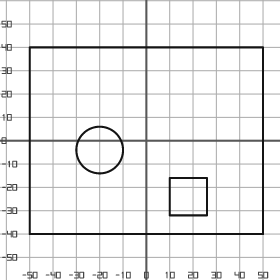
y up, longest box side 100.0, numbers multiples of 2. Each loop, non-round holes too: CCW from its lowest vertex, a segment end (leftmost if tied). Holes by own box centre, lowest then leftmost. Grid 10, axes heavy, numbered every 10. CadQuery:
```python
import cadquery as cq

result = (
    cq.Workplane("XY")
    .moveTo(-50.0, -40.0)
    .lineTo(50.0, -40.0)
    .lineTo(50.0, 40.0)
    .lineTo(-50.0, 40.0)
    .close()
    .moveTo(10.0, -32.0)
    .lineTo(26.0, -32.0)
    .lineTo(26.0, -16.0)
    .lineTo(10.0, -16.0)
    .close()
    .moveTo(-20.0, -4.0)
    .circle(10.0)
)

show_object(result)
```